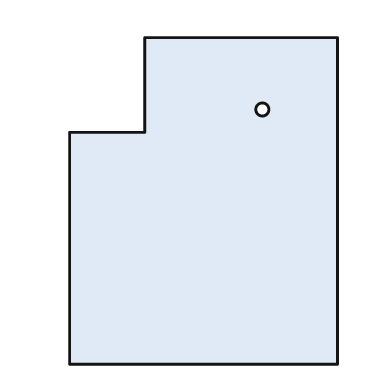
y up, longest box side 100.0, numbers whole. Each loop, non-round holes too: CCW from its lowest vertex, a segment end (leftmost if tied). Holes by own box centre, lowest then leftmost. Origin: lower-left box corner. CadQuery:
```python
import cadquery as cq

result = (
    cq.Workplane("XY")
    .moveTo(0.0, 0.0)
    .lineTo(82.0, 0.0)
    .lineTo(82.0, 100.0)
    .lineTo(23.0, 100.0)
    .lineTo(23.0, 71.0)
    .lineTo(0.0, 71.0)
    .close()
    .moveTo(59.0, 78.0)
    .circle(2.0)
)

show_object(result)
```